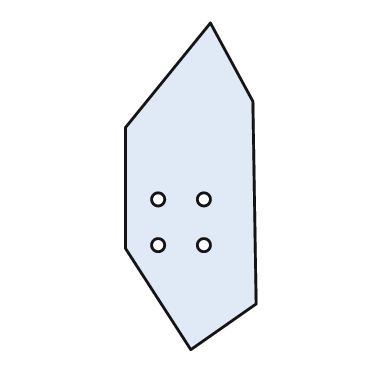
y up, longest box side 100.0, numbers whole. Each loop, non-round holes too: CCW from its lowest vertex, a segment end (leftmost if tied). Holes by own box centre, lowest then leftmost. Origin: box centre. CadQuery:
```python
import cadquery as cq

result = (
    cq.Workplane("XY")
    .moveTo(0.0, -50.0)
    .lineTo(20.0, -36.0)
    .lineTo(19.0, 26.0)
    .lineTo(6.0, 50.0)
    .lineTo(-20.0, 18.0)
    .lineTo(-20.0, -19.0)
    .close()
    .moveTo(-10.0, -18.0)
    .circle(2.0)
    .moveTo(4.0, -18.0)
    .circle(2.0)
    .moveTo(-10.0, -4.0)
    .circle(2.0)
    .moveTo(4.0, -4.0)
    .circle(2.0)
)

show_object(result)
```